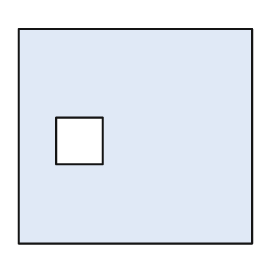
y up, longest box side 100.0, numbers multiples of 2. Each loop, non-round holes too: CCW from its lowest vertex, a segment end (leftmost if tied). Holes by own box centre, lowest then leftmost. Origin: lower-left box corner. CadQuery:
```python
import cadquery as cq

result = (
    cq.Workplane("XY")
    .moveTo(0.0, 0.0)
    .lineTo(100.0, 0.0)
    .lineTo(100.0, 92.0)
    .lineTo(0.0, 92.0)
    .close()
    .moveTo(16.0, 34.0)
    .lineTo(36.0, 34.0)
    .lineTo(36.0, 54.0)
    .lineTo(16.0, 54.0)
    .close()
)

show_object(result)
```